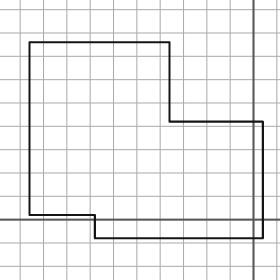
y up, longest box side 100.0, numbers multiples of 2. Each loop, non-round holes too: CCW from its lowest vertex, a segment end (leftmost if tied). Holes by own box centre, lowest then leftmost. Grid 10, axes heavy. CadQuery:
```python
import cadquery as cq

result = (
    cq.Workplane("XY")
    .moveTo(-68.0, -8.0)
    .lineTo(4.0, -8.0)
    .lineTo(4.0, 42.0)
    .lineTo(-36.0, 42.0)
    .lineTo(-36.0, 76.0)
    .lineTo(-96.0, 76.0)
    .lineTo(-96.0, 2.0)
    .lineTo(-68.0, 2.0)
    .close()
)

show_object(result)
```